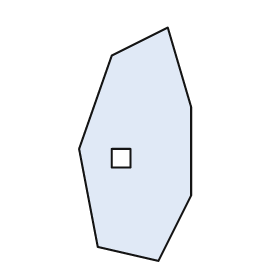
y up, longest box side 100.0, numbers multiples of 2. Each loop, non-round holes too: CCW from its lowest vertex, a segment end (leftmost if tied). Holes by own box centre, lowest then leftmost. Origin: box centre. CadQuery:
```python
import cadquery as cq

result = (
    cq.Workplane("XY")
    .moveTo(10.0, -50.0)
    .lineTo(24.0, -22.0)
    .lineTo(24.0, 16.0)
    .lineTo(14.0, 50.0)
    .lineTo(-10.0, 38.0)
    .lineTo(-24.0, -2.0)
    .lineTo(-16.0, -44.0)
    .close()
    .moveTo(-10.0, -10.0)
    .lineTo(-2.0, -10.0)
    .lineTo(-2.0, -2.0)
    .lineTo(-10.0, -2.0)
    .close()
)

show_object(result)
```